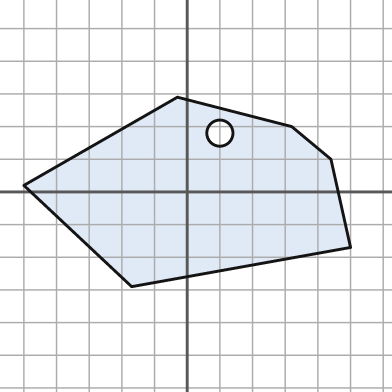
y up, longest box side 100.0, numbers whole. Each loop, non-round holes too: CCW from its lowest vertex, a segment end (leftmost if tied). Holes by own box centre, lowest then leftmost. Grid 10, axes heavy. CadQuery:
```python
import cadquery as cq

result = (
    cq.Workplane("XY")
    .moveTo(-17.0, -29.0)
    .lineTo(50.0, -17.0)
    .lineTo(44.0, 10.0)
    .lineTo(32.0, 20.0)
    .lineTo(-3.0, 29.0)
    .lineTo(-50.0, 2.0)
    .close()
    .moveTo(10.0, 18.0)
    .circle(4.0)
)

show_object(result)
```